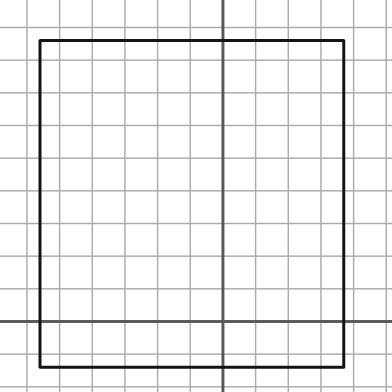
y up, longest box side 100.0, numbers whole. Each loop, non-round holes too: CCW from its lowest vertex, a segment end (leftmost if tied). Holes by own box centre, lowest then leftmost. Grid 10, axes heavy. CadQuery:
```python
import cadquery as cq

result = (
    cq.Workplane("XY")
    .moveTo(-56.0, -14.0)
    .lineTo(37.0, -14.0)
    .lineTo(37.0, 86.0)
    .lineTo(-56.0, 86.0)
    .close()
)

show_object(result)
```